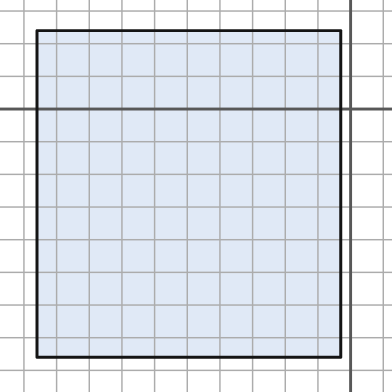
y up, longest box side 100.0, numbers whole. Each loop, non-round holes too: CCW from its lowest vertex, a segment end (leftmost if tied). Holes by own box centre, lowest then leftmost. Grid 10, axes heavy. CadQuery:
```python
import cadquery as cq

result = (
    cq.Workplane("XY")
    .moveTo(-96.0, -76.0)
    .lineTo(-3.0, -76.0)
    .lineTo(-3.0, 24.0)
    .lineTo(-96.0, 24.0)
    .close()
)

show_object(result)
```